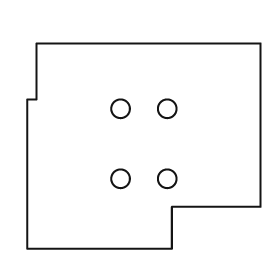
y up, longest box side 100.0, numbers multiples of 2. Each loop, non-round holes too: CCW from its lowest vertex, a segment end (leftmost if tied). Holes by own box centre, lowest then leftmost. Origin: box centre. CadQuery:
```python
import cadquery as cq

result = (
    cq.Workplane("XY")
    .moveTo(-50.0, -44.0)
    .lineTo(12.0, -44.0)
    .lineTo(12.0, -26.0)
    .lineTo(50.0, -26.0)
    .lineTo(50.0, 44.0)
    .lineTo(-46.0, 44.0)
    .lineTo(-46.0, 20.0)
    .lineTo(-50.0, 20.0)
    .close()
    .moveTo(-10.0, -14.0)
    .circle(4.0)
    .moveTo(10.0, -14.0)
    .circle(4.0)
    .moveTo(-10.0, 16.0)
    .circle(4.0)
    .moveTo(10.0, 16.0)
    .circle(4.0)
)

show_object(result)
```